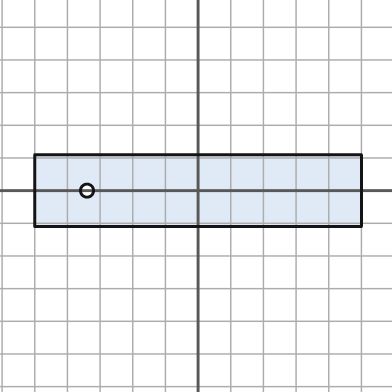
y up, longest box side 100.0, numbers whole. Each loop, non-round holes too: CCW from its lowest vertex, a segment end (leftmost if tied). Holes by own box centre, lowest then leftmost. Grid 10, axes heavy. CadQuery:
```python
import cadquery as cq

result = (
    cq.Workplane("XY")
    .moveTo(-50.0, -11.0)
    .lineTo(50.0, -11.0)
    .lineTo(50.0, 11.0)
    .lineTo(-50.0, 11.0)
    .close()
    .moveTo(-34.0, 0.0)
    .circle(2.0)
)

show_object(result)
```